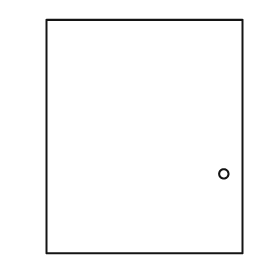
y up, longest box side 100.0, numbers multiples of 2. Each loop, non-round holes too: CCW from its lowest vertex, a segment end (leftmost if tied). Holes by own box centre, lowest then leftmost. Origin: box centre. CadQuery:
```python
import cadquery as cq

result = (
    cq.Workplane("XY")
    .moveTo(-42.0, -50.0)
    .lineTo(42.0, -50.0)
    .lineTo(42.0, 50.0)
    .lineTo(-42.0, 50.0)
    .close()
    .moveTo(34.0, -16.0)
    .circle(2.0)
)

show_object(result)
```